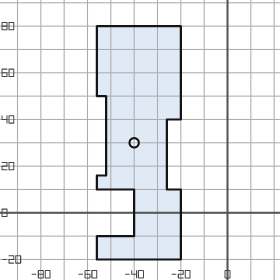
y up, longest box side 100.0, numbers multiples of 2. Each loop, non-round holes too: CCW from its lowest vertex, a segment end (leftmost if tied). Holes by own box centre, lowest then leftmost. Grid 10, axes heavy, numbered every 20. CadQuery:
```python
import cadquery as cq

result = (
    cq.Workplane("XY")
    .moveTo(-56.0, -20.0)
    .lineTo(-20.0, -20.0)
    .lineTo(-20.0, 10.0)
    .lineTo(-26.0, 10.0)
    .lineTo(-26.0, 40.0)
    .lineTo(-20.0, 40.0)
    .lineTo(-20.0, 80.0)
    .lineTo(-56.0, 80.0)
    .lineTo(-56.0, 50.0)
    .lineTo(-52.0, 50.0)
    .lineTo(-52.0, 16.0)
    .lineTo(-56.0, 16.0)
    .lineTo(-56.0, 10.0)
    .lineTo(-40.0, 10.0)
    .lineTo(-40.0, -10.0)
    .lineTo(-56.0, -10.0)
    .close()
    .moveTo(-40.0, 30.0)
    .circle(2.0)
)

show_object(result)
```